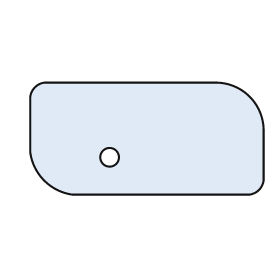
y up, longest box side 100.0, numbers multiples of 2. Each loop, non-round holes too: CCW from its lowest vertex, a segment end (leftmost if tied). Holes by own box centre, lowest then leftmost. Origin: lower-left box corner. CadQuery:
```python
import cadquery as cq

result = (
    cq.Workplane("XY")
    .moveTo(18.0, 0.0)
    .lineTo(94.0, 0.0)
    .threePointArc((98.0, 2.0), (100.0, 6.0))
    .lineTo(100.0, 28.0)
    .threePointArc((94.0, 42.0), (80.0, 48.0))
    .lineTo(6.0, 48.0)
    .threePointArc((2.0, 46.0), (0.0, 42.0))
    .lineTo(0.0, 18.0)
    .threePointArc((6.0, 6.0), (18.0, 0.0))
    .close()
    .moveTo(34.0, 16.0)
    .circle(4.0)
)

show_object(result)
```